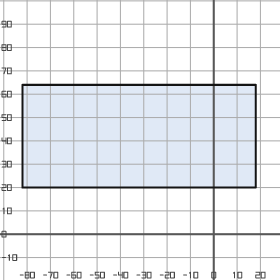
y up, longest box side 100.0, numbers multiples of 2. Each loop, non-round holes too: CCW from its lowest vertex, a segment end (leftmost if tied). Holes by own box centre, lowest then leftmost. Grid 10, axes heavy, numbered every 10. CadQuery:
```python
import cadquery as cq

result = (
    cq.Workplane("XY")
    .moveTo(-82.0, 20.0)
    .lineTo(18.0, 20.0)
    .lineTo(18.0, 64.0)
    .lineTo(-82.0, 64.0)
    .close()
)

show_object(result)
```